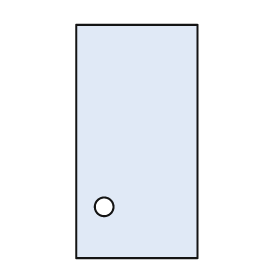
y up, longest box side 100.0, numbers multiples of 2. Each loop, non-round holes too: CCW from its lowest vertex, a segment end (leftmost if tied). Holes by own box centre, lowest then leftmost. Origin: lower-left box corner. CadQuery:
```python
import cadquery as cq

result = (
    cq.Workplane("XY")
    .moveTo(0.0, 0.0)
    .lineTo(52.0, 0.0)
    .lineTo(52.0, 100.0)
    .lineTo(0.0, 100.0)
    .close()
    .moveTo(12.0, 22.0)
    .circle(4.0)
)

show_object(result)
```